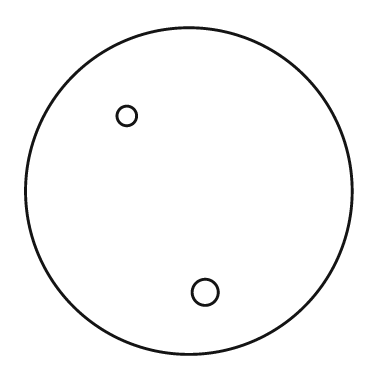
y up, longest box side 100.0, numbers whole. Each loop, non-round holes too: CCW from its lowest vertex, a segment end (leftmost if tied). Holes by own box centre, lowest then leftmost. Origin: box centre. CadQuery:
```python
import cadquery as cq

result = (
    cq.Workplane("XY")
    .moveTo(0.0, 0.0)
    .circle(50.0)
    .moveTo(5.0, -31.0)
    .circle(4.0)
    .moveTo(-19.0, 23.0)
    .circle(3.0)
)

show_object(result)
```